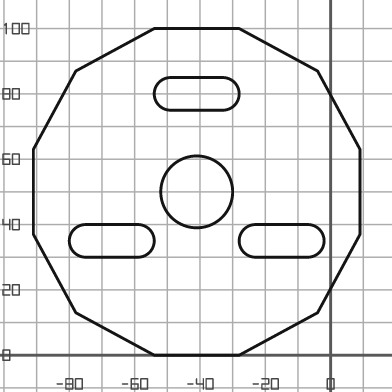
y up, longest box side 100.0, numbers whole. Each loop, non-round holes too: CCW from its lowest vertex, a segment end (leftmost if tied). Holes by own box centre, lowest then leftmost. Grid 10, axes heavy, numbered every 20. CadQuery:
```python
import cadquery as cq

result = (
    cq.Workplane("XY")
    .moveTo(-54.0, 0.0)
    .lineTo(-28.0, 0.0)
    .lineTo(-4.0, 13.0)
    .lineTo(9.0, 37.0)
    .lineTo(9.0, 63.0)
    .lineTo(-4.0, 87.0)
    .lineTo(-28.0, 100.0)
    .lineTo(-54.0, 100.0)
    .lineTo(-78.0, 87.0)
    .lineTo(-91.0, 63.0)
    .lineTo(-91.0, 37.0)
    .lineTo(-78.0, 13.0)
    .close()
    .moveTo(-75.0, 30.0)
    .lineTo(-59.0, 30.0)
    .threePointArc((-54.0, 35.0), (-59.0, 40.0))
    .lineTo(-75.0, 40.0)
    .threePointArc((-80.0, 35.0), (-75.0, 30.0))
    .close()
    .moveTo(-23.0, 30.0)
    .lineTo(-7.0, 30.0)
    .threePointArc((-2.0, 35.0), (-7.0, 40.0))
    .lineTo(-23.0, 40.0)
    .threePointArc((-28.0, 35.0), (-23.0, 30.0))
    .close()
    .moveTo(-41.0, 50.0)
    .circle(11.0)
    .moveTo(-49.0, 75.0)
    .lineTo(-33.0, 75.0)
    .threePointArc((-28.0, 80.0), (-33.0, 85.0))
    .lineTo(-49.0, 85.0)
    .threePointArc((-54.0, 80.0), (-49.0, 75.0))
    .close()
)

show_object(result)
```